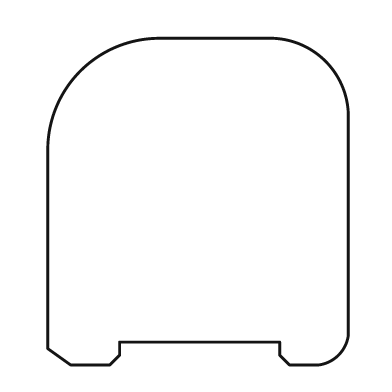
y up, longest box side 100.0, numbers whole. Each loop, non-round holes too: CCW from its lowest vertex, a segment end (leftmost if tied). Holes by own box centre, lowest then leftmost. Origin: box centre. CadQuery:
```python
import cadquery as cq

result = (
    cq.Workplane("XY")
    .moveTo(-39.0, -50.0)
    .lineTo(-27.0, -50.0)
    .lineTo(-24.0, -47.0)
    .lineTo(-24.0, -43.0)
    .lineTo(25.0, -43.0)
    .lineTo(25.0, -47.0)
    .lineTo(28.0, -50.0)
    .lineTo(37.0, -50.0)
    .threePointArc((43.0, -47.0), (46.0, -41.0))
    .lineTo(46.0, 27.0)
    .threePointArc((39.0, 43.0), (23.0, 50.0))
    .lineTo(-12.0, 50.0)
    .threePointArc((-36.0, 40.0), (-46.0, 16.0))
    .lineTo(-46.0, -45.0)
    .close()
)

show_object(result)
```